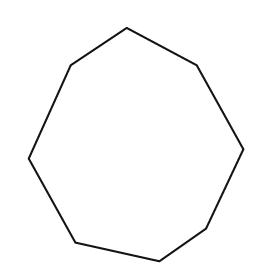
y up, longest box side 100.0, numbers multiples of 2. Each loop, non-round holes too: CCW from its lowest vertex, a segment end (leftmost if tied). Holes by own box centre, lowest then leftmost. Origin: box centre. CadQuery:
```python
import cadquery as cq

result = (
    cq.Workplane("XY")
    .moveTo(10.0, -50.0)
    .lineTo(30.0, -36.0)
    .lineTo(46.0, -2.0)
    .lineTo(26.0, 34.0)
    .lineTo(-4.0, 50.0)
    .lineTo(-28.0, 34.0)
    .lineTo(-46.0, -6.0)
    .lineTo(-26.0, -42.0)
    .close()
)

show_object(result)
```